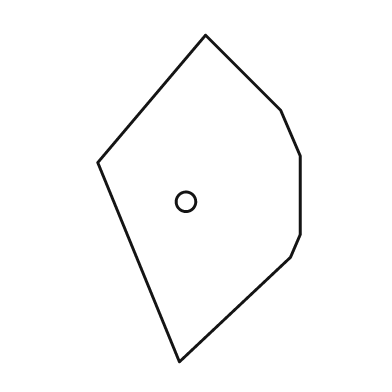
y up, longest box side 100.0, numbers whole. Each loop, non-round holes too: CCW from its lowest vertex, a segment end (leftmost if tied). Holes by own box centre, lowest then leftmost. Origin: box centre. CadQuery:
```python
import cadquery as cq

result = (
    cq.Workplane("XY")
    .moveTo(-6.0, -50.0)
    .lineTo(28.0, -18.0)
    .lineTo(31.0, -11.0)
    .lineTo(31.0, 13.0)
    .lineTo(25.0, 27.0)
    .lineTo(2.0, 50.0)
    .lineTo(-31.0, 11.0)
    .close()
    .moveTo(-4.0, -1.0)
    .circle(3.0)
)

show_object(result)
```